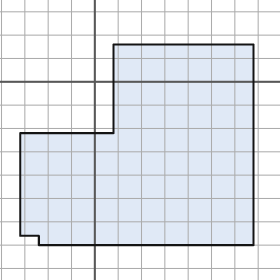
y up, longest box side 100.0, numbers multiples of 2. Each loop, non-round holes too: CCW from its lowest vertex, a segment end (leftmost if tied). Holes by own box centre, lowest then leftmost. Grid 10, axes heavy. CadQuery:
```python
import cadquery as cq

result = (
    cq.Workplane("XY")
    .moveTo(-24.0, -70.0)
    .lineTo(68.0, -70.0)
    .lineTo(68.0, 16.0)
    .lineTo(8.0, 16.0)
    .lineTo(8.0, -22.0)
    .lineTo(-32.0, -22.0)
    .lineTo(-32.0, -66.0)
    .lineTo(-24.0, -66.0)
    .close()
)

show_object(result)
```